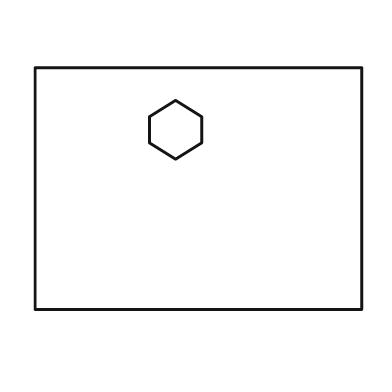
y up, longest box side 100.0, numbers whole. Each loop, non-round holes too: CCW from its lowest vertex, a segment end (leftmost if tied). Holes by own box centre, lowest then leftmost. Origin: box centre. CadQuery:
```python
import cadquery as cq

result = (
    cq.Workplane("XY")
    .moveTo(-50.0, -37.0)
    .lineTo(50.0, -37.0)
    .lineTo(50.0, 37.0)
    .lineTo(-50.0, 37.0)
    .close()
    .moveTo(-7.0, 9.0)
    .lineTo(1.0, 14.0)
    .lineTo(1.0, 22.0)
    .lineTo(-7.0, 27.0)
    .lineTo(-15.0, 22.0)
    .lineTo(-15.0, 14.0)
    .close()
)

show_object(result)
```